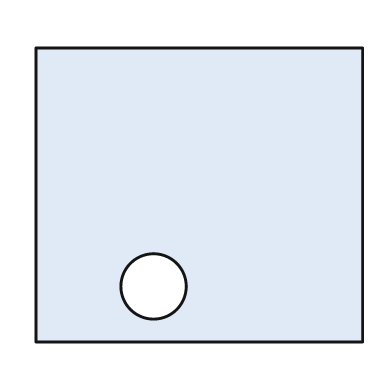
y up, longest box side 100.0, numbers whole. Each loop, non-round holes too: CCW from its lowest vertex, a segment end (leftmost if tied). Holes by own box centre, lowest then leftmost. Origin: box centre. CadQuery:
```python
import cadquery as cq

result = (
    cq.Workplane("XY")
    .moveTo(-50.0, -45.0)
    .lineTo(50.0, -45.0)
    .lineTo(50.0, 45.0)
    .lineTo(-50.0, 45.0)
    .close()
    .moveTo(-14.0, -28.0)
    .circle(10.0)
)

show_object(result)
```